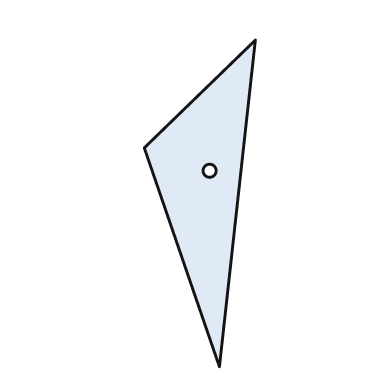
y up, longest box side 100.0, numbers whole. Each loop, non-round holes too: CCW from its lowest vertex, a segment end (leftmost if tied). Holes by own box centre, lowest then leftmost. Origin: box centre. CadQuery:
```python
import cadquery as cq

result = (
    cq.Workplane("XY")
    .moveTo(6.0, -50.0)
    .lineTo(17.0, 50.0)
    .lineTo(-17.0, 17.0)
    .close()
    .moveTo(3.0, 10.0)
    .circle(2.0)
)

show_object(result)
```